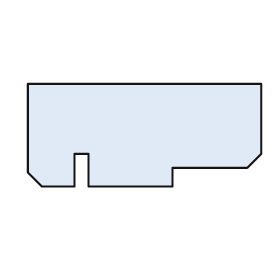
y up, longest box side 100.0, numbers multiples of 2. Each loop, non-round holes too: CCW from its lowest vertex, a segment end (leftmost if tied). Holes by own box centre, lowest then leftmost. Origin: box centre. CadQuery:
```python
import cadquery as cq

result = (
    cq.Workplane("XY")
    .moveTo(-44.0, -22.0)
    .lineTo(-30.0, -22.0)
    .lineTo(-30.0, -8.0)
    .lineTo(-24.0, -8.0)
    .lineTo(-24.0, -22.0)
    .lineTo(12.0, -22.0)
    .lineTo(12.0, -14.0)
    .lineTo(44.0, -14.0)
    .lineTo(50.0, -8.0)
    .lineTo(50.0, 22.0)
    .lineTo(-50.0, 22.0)
    .lineTo(-50.0, -16.0)
    .close()
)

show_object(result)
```